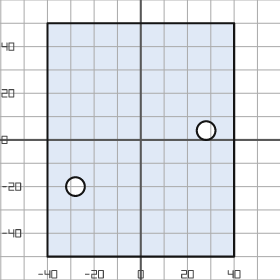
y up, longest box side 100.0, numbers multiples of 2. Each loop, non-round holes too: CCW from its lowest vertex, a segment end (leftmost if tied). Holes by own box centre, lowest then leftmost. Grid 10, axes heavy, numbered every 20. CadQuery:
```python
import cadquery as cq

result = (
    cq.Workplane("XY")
    .moveTo(-40.0, -50.0)
    .lineTo(40.0, -50.0)
    .lineTo(40.0, 50.0)
    .lineTo(-40.0, 50.0)
    .close()
    .moveTo(-28.0, -20.0)
    .circle(4.0)
    .moveTo(28.0, 4.0)
    .circle(4.0)
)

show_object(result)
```